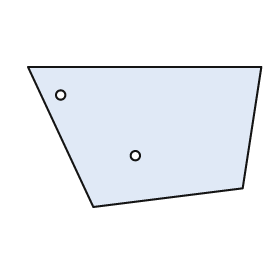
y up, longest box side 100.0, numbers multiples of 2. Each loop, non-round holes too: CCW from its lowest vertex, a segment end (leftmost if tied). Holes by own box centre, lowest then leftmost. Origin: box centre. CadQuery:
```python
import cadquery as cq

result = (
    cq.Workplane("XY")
    .moveTo(-22.0, -30.0)
    .lineTo(42.0, -22.0)
    .lineTo(50.0, 30.0)
    .lineTo(-50.0, 30.0)
    .close()
    .moveTo(-4.0, -8.0)
    .circle(2.0)
    .moveTo(-36.0, 18.0)
    .circle(2.0)
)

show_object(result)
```